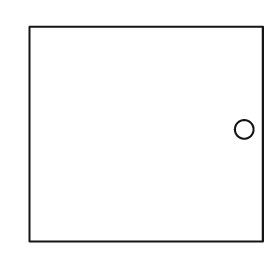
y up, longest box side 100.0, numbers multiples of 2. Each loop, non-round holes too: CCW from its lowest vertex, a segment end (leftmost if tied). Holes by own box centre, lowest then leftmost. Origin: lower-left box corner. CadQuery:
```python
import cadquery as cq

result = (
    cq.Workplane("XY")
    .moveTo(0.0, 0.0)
    .lineTo(100.0, 0.0)
    .lineTo(100.0, 92.0)
    .lineTo(0.0, 92.0)
    .close()
    .moveTo(92.0, 48.0)
    .circle(4.0)
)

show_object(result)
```